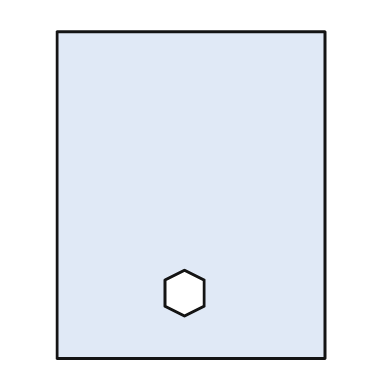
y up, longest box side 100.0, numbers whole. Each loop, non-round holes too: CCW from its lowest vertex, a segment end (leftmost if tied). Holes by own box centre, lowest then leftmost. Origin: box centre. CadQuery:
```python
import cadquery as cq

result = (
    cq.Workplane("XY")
    .moveTo(-41.0, -50.0)
    .lineTo(41.0, -50.0)
    .lineTo(41.0, 50.0)
    .lineTo(-41.0, 50.0)
    .close()
    .moveTo(-2.0, -37.0)
    .lineTo(4.0, -34.0)
    .lineTo(4.0, -26.0)
    .lineTo(-2.0, -23.0)
    .lineTo(-8.0, -26.0)
    .lineTo(-8.0, -34.0)
    .close()
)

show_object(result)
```